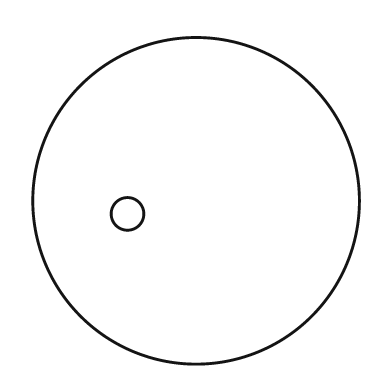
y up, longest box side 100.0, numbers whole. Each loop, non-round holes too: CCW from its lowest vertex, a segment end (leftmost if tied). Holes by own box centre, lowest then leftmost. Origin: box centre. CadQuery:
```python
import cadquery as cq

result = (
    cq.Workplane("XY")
    .moveTo(0.0, 0.0)
    .circle(50.0)
    .moveTo(-21.0, -4.0)
    .circle(5.0)
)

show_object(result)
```